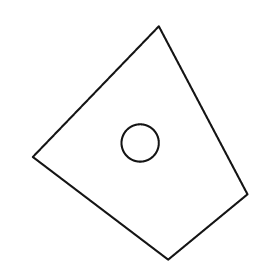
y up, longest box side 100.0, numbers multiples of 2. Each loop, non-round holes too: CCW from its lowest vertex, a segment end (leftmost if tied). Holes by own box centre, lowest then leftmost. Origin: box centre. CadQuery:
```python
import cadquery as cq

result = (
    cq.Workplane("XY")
    .moveTo(12.0, -50.0)
    .lineTo(46.0, -22.0)
    .lineTo(8.0, 50.0)
    .lineTo(-46.0, -6.0)
    .close()
    .moveTo(0.0, 0.0)
    .circle(8.0)
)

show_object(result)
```